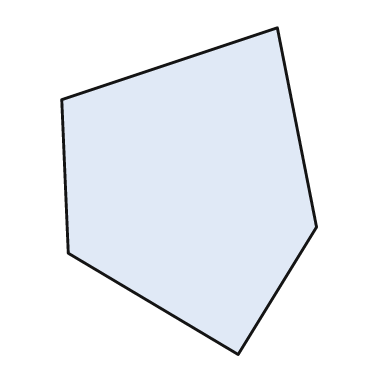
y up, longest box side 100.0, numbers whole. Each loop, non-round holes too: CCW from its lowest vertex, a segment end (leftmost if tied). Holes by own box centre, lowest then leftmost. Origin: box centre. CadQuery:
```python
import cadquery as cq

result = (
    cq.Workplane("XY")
    .moveTo(15.0, -50.0)
    .lineTo(39.0, -11.0)
    .lineTo(27.0, 50.0)
    .lineTo(-39.0, 28.0)
    .lineTo(-37.0, -19.0)
    .close()
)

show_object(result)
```